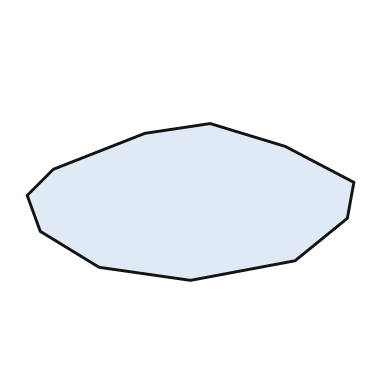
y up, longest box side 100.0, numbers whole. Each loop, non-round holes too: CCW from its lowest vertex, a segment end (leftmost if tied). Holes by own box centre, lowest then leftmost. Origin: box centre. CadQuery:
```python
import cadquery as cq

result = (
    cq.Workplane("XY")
    .moveTo(0.0, -24.0)
    .lineTo(32.0, -18.0)
    .lineTo(48.0, -5.0)
    .lineTo(50.0, 6.0)
    .lineTo(29.0, 17.0)
    .lineTo(6.0, 24.0)
    .lineTo(-14.0, 21.0)
    .lineTo(-42.0, 10.0)
    .lineTo(-50.0, 2.0)
    .lineTo(-46.0, -9.0)
    .lineTo(-28.0, -20.0)
    .close()
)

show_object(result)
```